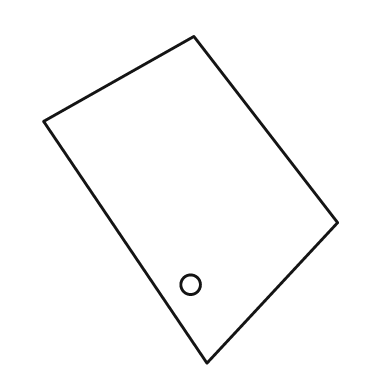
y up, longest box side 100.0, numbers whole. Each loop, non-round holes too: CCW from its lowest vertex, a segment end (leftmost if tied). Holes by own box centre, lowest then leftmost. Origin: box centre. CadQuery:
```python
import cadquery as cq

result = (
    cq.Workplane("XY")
    .moveTo(5.0, -50.0)
    .lineTo(45.0, -7.0)
    .lineTo(1.0, 50.0)
    .lineTo(-45.0, 24.0)
    .close()
    .moveTo(0.0, -26.0)
    .circle(3.0)
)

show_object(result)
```